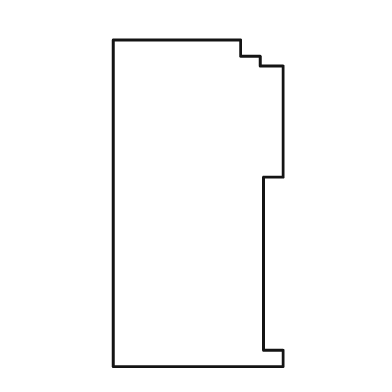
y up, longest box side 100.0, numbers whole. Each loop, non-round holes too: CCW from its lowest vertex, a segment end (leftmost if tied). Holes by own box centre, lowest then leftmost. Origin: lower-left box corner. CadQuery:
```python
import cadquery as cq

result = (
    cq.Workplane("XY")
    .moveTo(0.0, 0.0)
    .lineTo(52.0, 0.0)
    .lineTo(52.0, 5.0)
    .lineTo(46.0, 5.0)
    .lineTo(46.0, 58.0)
    .lineTo(52.0, 58.0)
    .lineTo(52.0, 92.0)
    .lineTo(45.0, 92.0)
    .lineTo(45.0, 95.0)
    .lineTo(39.0, 95.0)
    .lineTo(39.0, 100.0)
    .lineTo(0.0, 100.0)
    .close()
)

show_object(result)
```